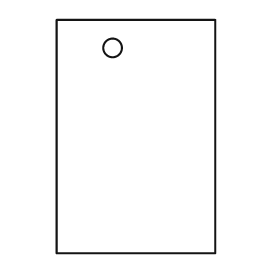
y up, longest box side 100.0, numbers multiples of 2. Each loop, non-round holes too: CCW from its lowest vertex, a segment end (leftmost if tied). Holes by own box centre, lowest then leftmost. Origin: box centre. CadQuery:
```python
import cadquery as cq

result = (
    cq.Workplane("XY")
    .moveTo(-34.0, -50.0)
    .lineTo(34.0, -50.0)
    .lineTo(34.0, 50.0)
    .lineTo(-34.0, 50.0)
    .close()
    .moveTo(-10.0, 38.0)
    .circle(4.0)
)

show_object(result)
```